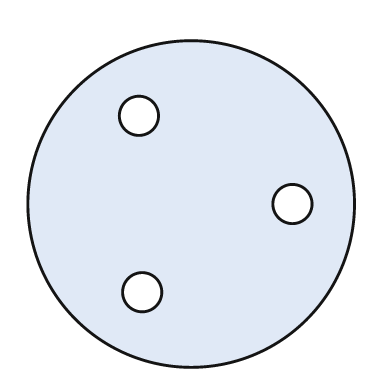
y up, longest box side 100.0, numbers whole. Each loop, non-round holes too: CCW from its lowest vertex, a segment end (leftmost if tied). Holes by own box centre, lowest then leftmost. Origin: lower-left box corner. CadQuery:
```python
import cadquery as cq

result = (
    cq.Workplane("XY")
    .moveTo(50.0, 50.0)
    .circle(50.0)
    .moveTo(35.0, 23.0)
    .circle(6.0)
    .moveTo(81.0, 50.0)
    .circle(6.0)
    .moveTo(34.0, 77.0)
    .circle(6.0)
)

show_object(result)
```